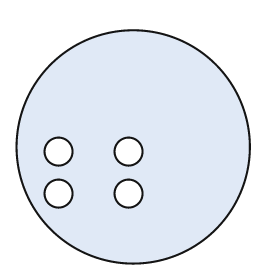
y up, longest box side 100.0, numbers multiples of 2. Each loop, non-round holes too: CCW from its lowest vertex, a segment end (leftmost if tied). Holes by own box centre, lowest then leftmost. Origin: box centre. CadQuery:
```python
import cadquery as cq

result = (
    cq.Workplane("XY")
    .moveTo(0.0, 0.0)
    .circle(50.0)
    .moveTo(-32.0, -20.0)
    .circle(6.0)
    .moveTo(-2.0, -20.0)
    .circle(6.0)
    .moveTo(-32.0, -2.0)
    .circle(6.0)
    .moveTo(-2.0, -2.0)
    .circle(6.0)
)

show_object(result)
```